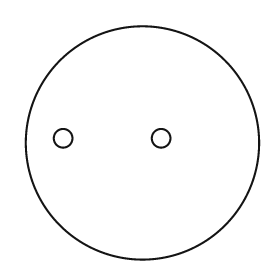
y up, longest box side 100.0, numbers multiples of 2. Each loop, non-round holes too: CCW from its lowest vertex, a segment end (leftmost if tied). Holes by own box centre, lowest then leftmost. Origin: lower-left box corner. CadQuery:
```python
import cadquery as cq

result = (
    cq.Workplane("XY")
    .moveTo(50.0, 50.0)
    .circle(50.0)
    .moveTo(16.0, 52.0)
    .circle(4.0)
    .moveTo(58.0, 52.0)
    .circle(4.0)
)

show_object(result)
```